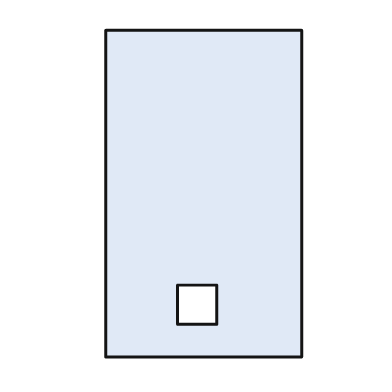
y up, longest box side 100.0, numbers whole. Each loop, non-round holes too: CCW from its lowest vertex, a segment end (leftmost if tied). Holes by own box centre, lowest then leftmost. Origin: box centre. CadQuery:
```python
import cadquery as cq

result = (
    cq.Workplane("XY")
    .moveTo(-30.0, -50.0)
    .lineTo(30.0, -50.0)
    .lineTo(30.0, 50.0)
    .lineTo(-30.0, 50.0)
    .close()
    .moveTo(-8.0, -40.0)
    .lineTo(4.0, -40.0)
    .lineTo(4.0, -28.0)
    .lineTo(-8.0, -28.0)
    .close()
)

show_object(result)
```